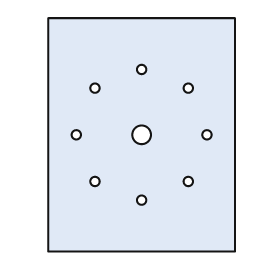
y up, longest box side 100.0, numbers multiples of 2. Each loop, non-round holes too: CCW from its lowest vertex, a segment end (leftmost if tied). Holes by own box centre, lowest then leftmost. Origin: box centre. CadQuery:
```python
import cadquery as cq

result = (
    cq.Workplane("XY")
    .moveTo(-40.0, -50.0)
    .lineTo(40.0, -50.0)
    .lineTo(40.0, 50.0)
    .lineTo(-40.0, 50.0)
    .close()
    .moveTo(0.0, -28.0)
    .circle(2.0)
    .moveTo(-20.0, -20.0)
    .circle(2.0)
    .moveTo(20.0, -20.0)
    .circle(2.0)
    .moveTo(-28.0, 0.0)
    .circle(2.0)
    .moveTo(0.0, 0.0)
    .circle(4.0)
    .moveTo(28.0, 0.0)
    .circle(2.0)
    .moveTo(-20.0, 20.0)
    .circle(2.0)
    .moveTo(20.0, 20.0)
    .circle(2.0)
    .moveTo(0.0, 28.0)
    .circle(2.0)
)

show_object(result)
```